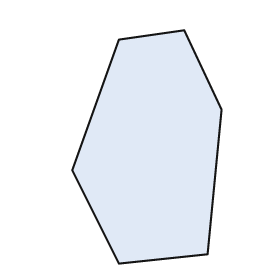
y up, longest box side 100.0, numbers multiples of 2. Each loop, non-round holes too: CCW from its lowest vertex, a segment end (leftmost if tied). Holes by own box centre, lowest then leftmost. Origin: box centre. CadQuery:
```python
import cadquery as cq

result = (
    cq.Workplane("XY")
    .moveTo(-12.0, -50.0)
    .lineTo(26.0, -46.0)
    .lineTo(32.0, 16.0)
    .lineTo(16.0, 50.0)
    .lineTo(-12.0, 46.0)
    .lineTo(-32.0, -10.0)
    .close()
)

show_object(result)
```